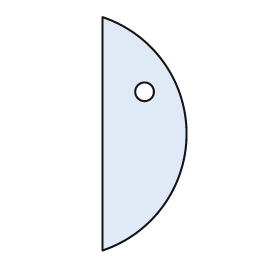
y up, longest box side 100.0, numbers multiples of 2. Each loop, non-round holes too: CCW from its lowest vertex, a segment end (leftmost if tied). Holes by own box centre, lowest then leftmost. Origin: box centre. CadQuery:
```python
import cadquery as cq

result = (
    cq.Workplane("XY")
    .moveTo(-18.0, -50.0)
    .threePointArc((18.0, 0.0), (-18.0, 50.0))
    .close()
    .moveTo(0.0, 18.0)
    .circle(4.0)
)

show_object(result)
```